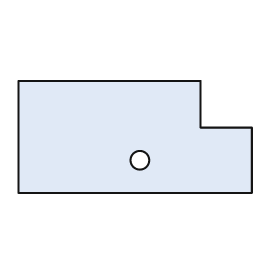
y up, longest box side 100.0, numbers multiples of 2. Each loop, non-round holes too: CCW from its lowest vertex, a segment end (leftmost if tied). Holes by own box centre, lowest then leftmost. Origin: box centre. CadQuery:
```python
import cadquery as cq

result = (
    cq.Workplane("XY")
    .moveTo(-50.0, -24.0)
    .lineTo(50.0, -24.0)
    .lineTo(50.0, 4.0)
    .lineTo(28.0, 4.0)
    .lineTo(28.0, 24.0)
    .lineTo(-50.0, 24.0)
    .close()
    .moveTo(2.0, -10.0)
    .circle(4.0)
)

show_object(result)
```